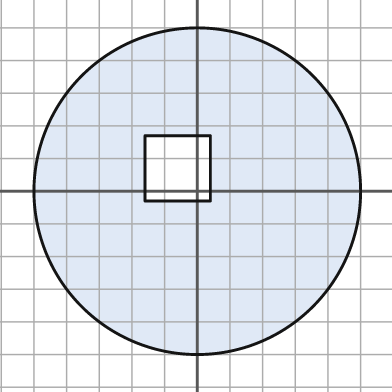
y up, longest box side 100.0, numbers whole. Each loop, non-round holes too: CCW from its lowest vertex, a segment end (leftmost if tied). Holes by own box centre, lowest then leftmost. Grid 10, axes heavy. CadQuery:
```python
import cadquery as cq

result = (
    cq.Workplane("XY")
    .moveTo(0.0, 0.0)
    .circle(50.0)
    .moveTo(-16.0, -3.0)
    .lineTo(4.0, -3.0)
    .lineTo(4.0, 17.0)
    .lineTo(-16.0, 17.0)
    .close()
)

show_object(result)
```